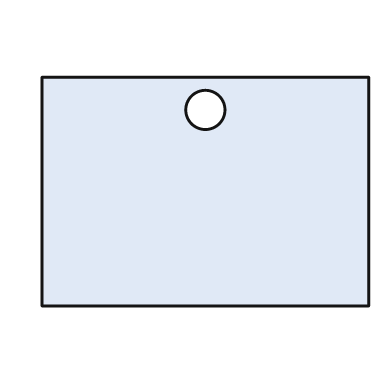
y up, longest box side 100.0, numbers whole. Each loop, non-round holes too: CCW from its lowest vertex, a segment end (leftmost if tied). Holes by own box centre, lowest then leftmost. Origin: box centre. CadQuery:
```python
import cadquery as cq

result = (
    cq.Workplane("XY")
    .moveTo(-50.0, -35.0)
    .lineTo(50.0, -35.0)
    .lineTo(50.0, 35.0)
    .lineTo(-50.0, 35.0)
    .close()
    .moveTo(0.0, 25.0)
    .circle(6.0)
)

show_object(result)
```